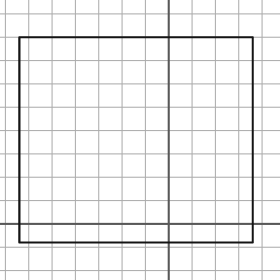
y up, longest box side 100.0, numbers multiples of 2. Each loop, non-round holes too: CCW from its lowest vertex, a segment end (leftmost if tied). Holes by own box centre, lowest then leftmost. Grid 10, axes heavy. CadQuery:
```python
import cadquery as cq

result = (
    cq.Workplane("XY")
    .moveTo(-64.0, -8.0)
    .lineTo(36.0, -8.0)
    .lineTo(36.0, 80.0)
    .lineTo(-64.0, 80.0)
    .close()
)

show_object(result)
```